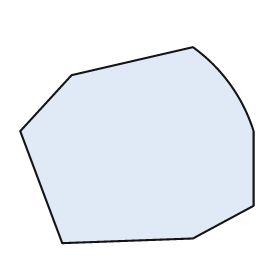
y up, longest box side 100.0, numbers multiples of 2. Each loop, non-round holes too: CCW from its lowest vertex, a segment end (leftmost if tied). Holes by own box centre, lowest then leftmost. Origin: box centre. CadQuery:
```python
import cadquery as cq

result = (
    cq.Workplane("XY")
    .moveTo(-32.0, -42.0)
    .lineTo(24.0, -40.0)
    .lineTo(50.0, -26.0)
    .lineTo(50.0, 6.0)
    .threePointArc((40.0, 26.0), (24.0, 42.0))
    .lineTo(-28.0, 30.0)
    .lineTo(-50.0, 6.0)
    .close()
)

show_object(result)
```